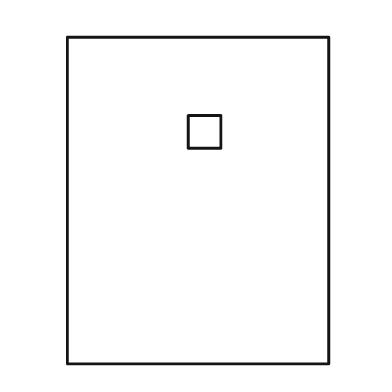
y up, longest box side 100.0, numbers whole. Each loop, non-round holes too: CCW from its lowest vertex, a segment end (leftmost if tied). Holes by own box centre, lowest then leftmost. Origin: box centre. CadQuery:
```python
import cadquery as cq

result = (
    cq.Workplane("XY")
    .moveTo(-40.0, -50.0)
    .lineTo(40.0, -50.0)
    .lineTo(40.0, 50.0)
    .lineTo(-40.0, 50.0)
    .close()
    .moveTo(-3.0, 16.0)
    .lineTo(7.0, 16.0)
    .lineTo(7.0, 26.0)
    .lineTo(-3.0, 26.0)
    .close()
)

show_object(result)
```